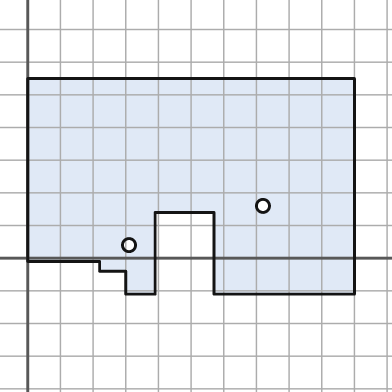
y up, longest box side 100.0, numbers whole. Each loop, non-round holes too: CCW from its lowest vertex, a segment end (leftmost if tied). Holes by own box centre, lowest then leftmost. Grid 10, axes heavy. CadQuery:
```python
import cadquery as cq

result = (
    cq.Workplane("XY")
    .moveTo(30.0, -11.0)
    .lineTo(39.0, -11.0)
    .lineTo(39.0, 14.0)
    .lineTo(57.0, 14.0)
    .lineTo(57.0, -11.0)
    .lineTo(100.0, -11.0)
    .lineTo(100.0, 55.0)
    .lineTo(0.0, 55.0)
    .lineTo(0.0, -1.0)
    .lineTo(22.0, -1.0)
    .lineTo(22.0, -4.0)
    .lineTo(30.0, -4.0)
    .close()
    .moveTo(31.0, 4.0)
    .circle(2.0)
    .moveTo(72.0, 16.0)
    .circle(2.0)
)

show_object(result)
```